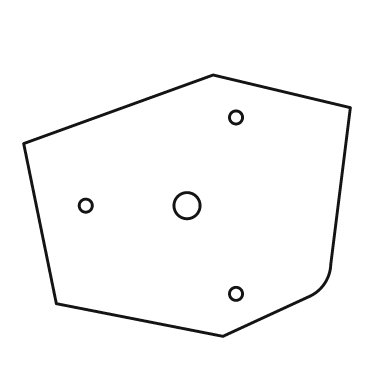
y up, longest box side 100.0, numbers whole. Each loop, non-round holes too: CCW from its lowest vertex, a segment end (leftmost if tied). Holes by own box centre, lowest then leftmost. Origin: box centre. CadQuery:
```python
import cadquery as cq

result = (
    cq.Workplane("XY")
    .moveTo(11.0, -40.0)
    .lineTo(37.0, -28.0)
    .threePointArc((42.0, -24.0), (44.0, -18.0))
    .lineTo(50.0, 30.0)
    .lineTo(8.0, 40.0)
    .lineTo(-50.0, 19.0)
    .lineTo(-40.0, -30.0)
    .close()
    .moveTo(15.0, -27.0)
    .circle(2.0)
    .moveTo(-31.0, 0.0)
    .circle(2.0)
    .moveTo(0.0, 0.0)
    .circle(4.0)
    .moveTo(15.0, 27.0)
    .circle(2.0)
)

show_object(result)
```